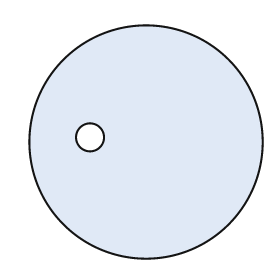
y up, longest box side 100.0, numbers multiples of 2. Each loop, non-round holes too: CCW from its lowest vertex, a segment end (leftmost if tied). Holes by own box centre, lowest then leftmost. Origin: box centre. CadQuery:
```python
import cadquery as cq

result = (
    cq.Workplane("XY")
    .moveTo(0.0, 0.0)
    .circle(50.0)
    .moveTo(-24.0, 2.0)
    .circle(6.0)
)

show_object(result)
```